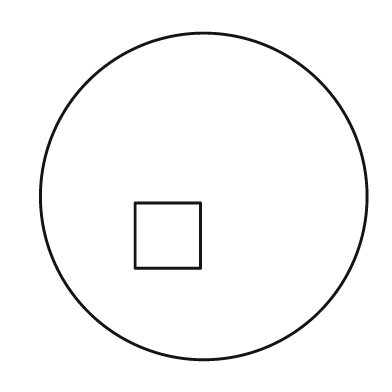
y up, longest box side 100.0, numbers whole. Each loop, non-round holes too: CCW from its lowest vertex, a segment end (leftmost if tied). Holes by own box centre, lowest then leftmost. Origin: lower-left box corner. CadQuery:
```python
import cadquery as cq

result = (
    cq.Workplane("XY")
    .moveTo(50.0, 50.0)
    .circle(50.0)
    .moveTo(29.0, 28.0)
    .lineTo(49.0, 28.0)
    .lineTo(49.0, 48.0)
    .lineTo(29.0, 48.0)
    .close()
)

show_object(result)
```